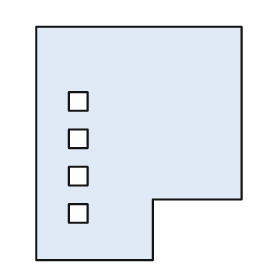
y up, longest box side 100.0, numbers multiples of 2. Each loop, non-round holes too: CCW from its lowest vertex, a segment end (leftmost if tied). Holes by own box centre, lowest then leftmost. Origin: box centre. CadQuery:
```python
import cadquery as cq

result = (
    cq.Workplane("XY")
    .moveTo(-44.0, -50.0)
    .lineTo(6.0, -50.0)
    .lineTo(6.0, -24.0)
    .lineTo(44.0, -24.0)
    .lineTo(44.0, 50.0)
    .lineTo(-44.0, 50.0)
    .close()
    .moveTo(-30.0, -34.0)
    .lineTo(-22.0, -34.0)
    .lineTo(-22.0, -26.0)
    .lineTo(-30.0, -26.0)
    .close()
    .moveTo(-30.0, -18.0)
    .lineTo(-22.0, -18.0)
    .lineTo(-22.0, -10.0)
    .lineTo(-30.0, -10.0)
    .close()
    .moveTo(-30.0, -2.0)
    .lineTo(-22.0, -2.0)
    .lineTo(-22.0, 6.0)
    .lineTo(-30.0, 6.0)
    .close()
    .moveTo(-30.0, 14.0)
    .lineTo(-22.0, 14.0)
    .lineTo(-22.0, 22.0)
    .lineTo(-30.0, 22.0)
    .close()
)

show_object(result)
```